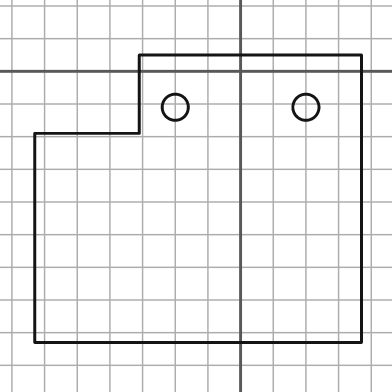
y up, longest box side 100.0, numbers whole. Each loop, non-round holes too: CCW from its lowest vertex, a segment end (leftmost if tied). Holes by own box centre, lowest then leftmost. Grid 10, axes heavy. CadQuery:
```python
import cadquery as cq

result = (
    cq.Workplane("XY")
    .moveTo(-63.0, -83.0)
    .lineTo(37.0, -83.0)
    .lineTo(37.0, 5.0)
    .lineTo(-31.0, 5.0)
    .lineTo(-31.0, -19.0)
    .lineTo(-63.0, -19.0)
    .close()
    .moveTo(-20.0, -11.0)
    .circle(4.0)
    .moveTo(20.0, -11.0)
    .circle(4.0)
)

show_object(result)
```